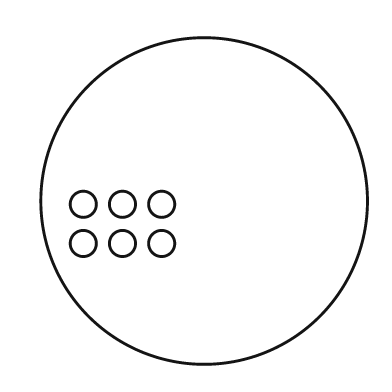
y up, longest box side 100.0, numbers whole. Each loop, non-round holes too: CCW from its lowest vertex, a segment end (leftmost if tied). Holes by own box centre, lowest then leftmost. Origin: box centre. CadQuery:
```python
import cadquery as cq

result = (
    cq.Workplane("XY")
    .moveTo(0.0, 0.0)
    .circle(50.0)
    .moveTo(-37.0, -13.0)
    .circle(4.0)
    .moveTo(-25.0, -13.0)
    .circle(4.0)
    .moveTo(-13.0, -13.0)
    .circle(4.0)
    .moveTo(-37.0, -1.0)
    .circle(4.0)
    .moveTo(-25.0, -1.0)
    .circle(4.0)
    .moveTo(-13.0, -1.0)
    .circle(4.0)
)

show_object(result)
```